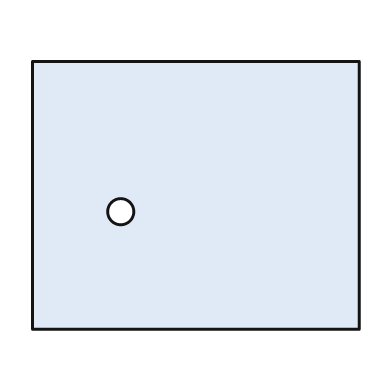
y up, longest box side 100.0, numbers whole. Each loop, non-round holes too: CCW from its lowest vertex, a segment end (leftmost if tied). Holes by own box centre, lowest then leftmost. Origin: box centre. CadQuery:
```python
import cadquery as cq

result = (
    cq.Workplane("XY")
    .moveTo(-50.0, -41.0)
    .lineTo(50.0, -41.0)
    .lineTo(50.0, 41.0)
    .lineTo(-50.0, 41.0)
    .close()
    .moveTo(-23.0, -5.0)
    .circle(4.0)
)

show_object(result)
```